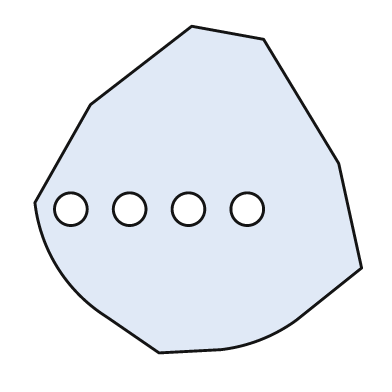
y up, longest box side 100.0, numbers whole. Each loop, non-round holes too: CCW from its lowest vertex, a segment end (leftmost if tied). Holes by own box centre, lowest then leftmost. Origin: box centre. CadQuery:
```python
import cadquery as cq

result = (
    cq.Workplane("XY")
    .moveTo(-12.0, -50.0)
    .lineTo(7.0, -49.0)
    .threePointArc((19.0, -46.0), (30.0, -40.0))
    .lineTo(50.0, -24.0)
    .lineTo(43.0, 8.0)
    .lineTo(20.0, 46.0)
    .lineTo(-2.0, 50.0)
    .lineTo(-33.0, 26.0)
    .lineTo(-50.0, -4.0)
    .threePointArc((-43.0, -24.0), (-28.0, -39.0))
    .close()
    .moveTo(-39.0, -6.0)
    .circle(5.0)
    .moveTo(-21.0, -6.0)
    .circle(5.0)
    .moveTo(-3.0, -6.0)
    .circle(5.0)
    .moveTo(15.0, -6.0)
    .circle(5.0)
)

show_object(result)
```